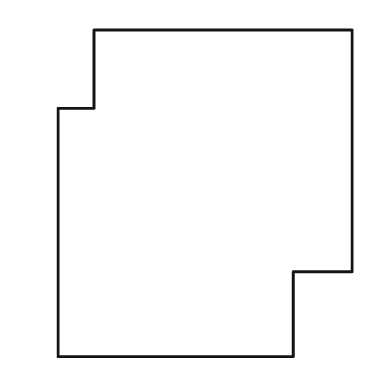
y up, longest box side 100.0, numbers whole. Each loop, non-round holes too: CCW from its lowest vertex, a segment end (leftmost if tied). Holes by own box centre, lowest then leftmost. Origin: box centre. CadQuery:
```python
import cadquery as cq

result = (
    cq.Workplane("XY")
    .moveTo(-45.0, -50.0)
    .lineTo(27.0, -50.0)
    .lineTo(27.0, -24.0)
    .lineTo(45.0, -24.0)
    .lineTo(45.0, 50.0)
    .lineTo(-34.0, 50.0)
    .lineTo(-34.0, 26.0)
    .lineTo(-45.0, 26.0)
    .close()
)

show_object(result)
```